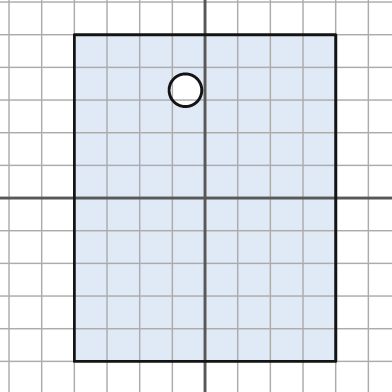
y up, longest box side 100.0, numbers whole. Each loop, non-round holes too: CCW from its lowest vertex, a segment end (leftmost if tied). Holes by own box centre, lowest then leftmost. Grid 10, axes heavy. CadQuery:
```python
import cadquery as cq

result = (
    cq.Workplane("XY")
    .moveTo(-40.0, -50.0)
    .lineTo(40.0, -50.0)
    .lineTo(40.0, 50.0)
    .lineTo(-40.0, 50.0)
    .close()
    .moveTo(-6.0, 33.0)
    .circle(5.0)
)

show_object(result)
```